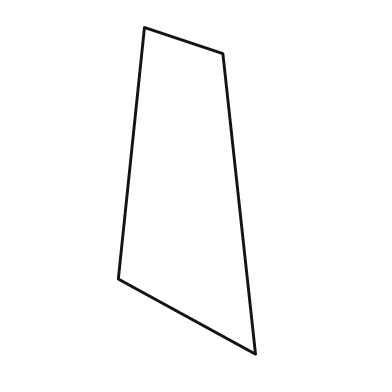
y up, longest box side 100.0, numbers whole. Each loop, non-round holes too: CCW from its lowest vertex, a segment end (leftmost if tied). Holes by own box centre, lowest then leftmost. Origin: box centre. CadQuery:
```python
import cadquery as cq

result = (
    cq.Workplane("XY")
    .moveTo(21.0, -50.0)
    .lineTo(11.0, 42.0)
    .lineTo(-13.0, 50.0)
    .lineTo(-21.0, -27.0)
    .close()
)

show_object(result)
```